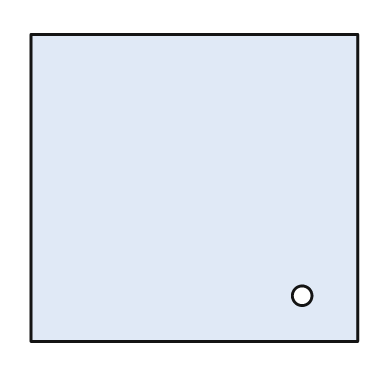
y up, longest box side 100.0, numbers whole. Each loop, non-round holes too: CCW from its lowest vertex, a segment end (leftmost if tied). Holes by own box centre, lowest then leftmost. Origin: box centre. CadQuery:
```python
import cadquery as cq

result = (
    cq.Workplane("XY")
    .moveTo(-50.0, -47.0)
    .lineTo(50.0, -47.0)
    .lineTo(50.0, 47.0)
    .lineTo(-50.0, 47.0)
    .close()
    .moveTo(33.0, -33.0)
    .circle(3.0)
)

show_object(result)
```